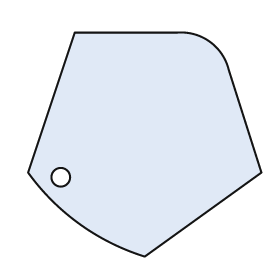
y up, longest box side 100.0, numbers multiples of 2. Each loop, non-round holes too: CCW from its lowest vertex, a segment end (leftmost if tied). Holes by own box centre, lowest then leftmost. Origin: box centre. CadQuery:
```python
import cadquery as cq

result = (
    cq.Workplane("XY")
    .moveTo(0.0, -48.0)
    .lineTo(50.0, -12.0)
    .lineTo(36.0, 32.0)
    .threePointArc((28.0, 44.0), (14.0, 48.0))
    .lineTo(-30.0, 48.0)
    .lineTo(-50.0, -12.0)
    .threePointArc((-28.0, -34.0), (0.0, -48.0))
    .close()
    .moveTo(-36.0, -14.0)
    .circle(4.0)
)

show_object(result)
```